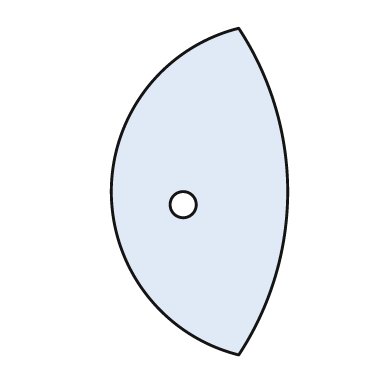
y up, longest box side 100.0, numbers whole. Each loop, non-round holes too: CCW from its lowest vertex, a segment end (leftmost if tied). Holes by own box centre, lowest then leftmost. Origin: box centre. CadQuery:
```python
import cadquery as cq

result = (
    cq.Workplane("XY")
    .moveTo(12.0, -50.0)
    .threePointArc((27.0, 0.0), (12.0, 50.0))
    .threePointArc((-27.0, 0.0), (12.0, -50.0))
    .close()
    .moveTo(-5.0, -4.0)
    .circle(4.0)
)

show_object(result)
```